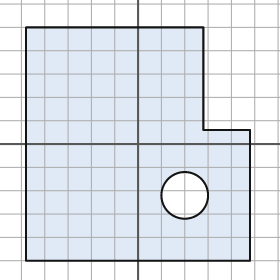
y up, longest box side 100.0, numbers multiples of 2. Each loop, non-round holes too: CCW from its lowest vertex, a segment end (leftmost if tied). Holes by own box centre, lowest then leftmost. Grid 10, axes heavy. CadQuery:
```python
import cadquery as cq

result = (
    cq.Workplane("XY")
    .moveTo(-48.0, -50.0)
    .lineTo(48.0, -50.0)
    .lineTo(48.0, 6.0)
    .lineTo(28.0, 6.0)
    .lineTo(28.0, 50.0)
    .lineTo(-48.0, 50.0)
    .close()
    .moveTo(20.0, -22.0)
    .circle(10.0)
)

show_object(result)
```